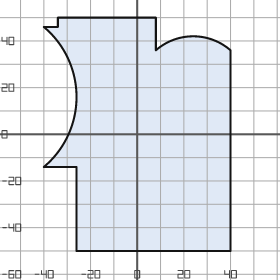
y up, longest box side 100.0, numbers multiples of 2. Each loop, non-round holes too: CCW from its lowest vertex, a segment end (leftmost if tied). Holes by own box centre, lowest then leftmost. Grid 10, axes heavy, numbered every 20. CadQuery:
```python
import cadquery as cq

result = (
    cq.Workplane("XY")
    .moveTo(-26.0, -50.0)
    .lineTo(40.0, -50.0)
    .lineTo(40.0, 36.0)
    .threePointArc((24.0, 42.0), (8.0, 36.0))
    .lineTo(8.0, 50.0)
    .lineTo(-34.0, 50.0)
    .lineTo(-34.0, 46.0)
    .lineTo(-40.0, 46.0)
    .threePointArc((-26.0, 16.0), (-40.0, -14.0))
    .lineTo(-26.0, -14.0)
    .close()
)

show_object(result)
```